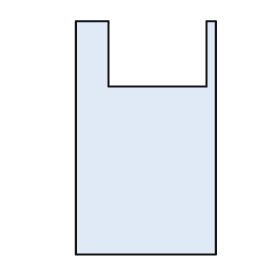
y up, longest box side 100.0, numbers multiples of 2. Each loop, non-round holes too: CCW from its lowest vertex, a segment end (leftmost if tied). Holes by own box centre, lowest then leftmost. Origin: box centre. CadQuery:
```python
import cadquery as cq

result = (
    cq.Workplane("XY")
    .moveTo(-30.0, -50.0)
    .lineTo(30.0, -50.0)
    .lineTo(30.0, 50.0)
    .lineTo(26.0, 50.0)
    .lineTo(26.0, 22.0)
    .lineTo(-16.0, 22.0)
    .lineTo(-16.0, 50.0)
    .lineTo(-30.0, 50.0)
    .close()
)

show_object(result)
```